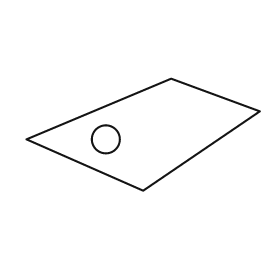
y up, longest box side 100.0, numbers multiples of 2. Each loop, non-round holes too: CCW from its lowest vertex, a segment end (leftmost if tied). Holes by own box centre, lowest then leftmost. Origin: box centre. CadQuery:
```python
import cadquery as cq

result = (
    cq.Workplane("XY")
    .moveTo(0.0, -24.0)
    .lineTo(50.0, 10.0)
    .lineTo(12.0, 24.0)
    .lineTo(-50.0, -2.0)
    .close()
    .moveTo(-16.0, -2.0)
    .circle(6.0)
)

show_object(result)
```